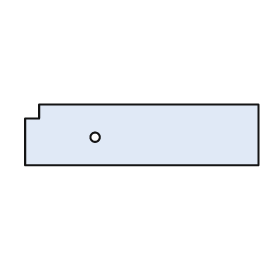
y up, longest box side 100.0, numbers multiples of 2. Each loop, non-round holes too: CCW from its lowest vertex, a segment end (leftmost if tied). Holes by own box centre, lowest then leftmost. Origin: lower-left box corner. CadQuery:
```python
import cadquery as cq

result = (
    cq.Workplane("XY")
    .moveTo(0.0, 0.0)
    .lineTo(100.0, 0.0)
    .lineTo(100.0, 26.0)
    .lineTo(6.0, 26.0)
    .lineTo(6.0, 20.0)
    .lineTo(0.0, 20.0)
    .close()
    .moveTo(30.0, 12.0)
    .circle(2.0)
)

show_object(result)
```